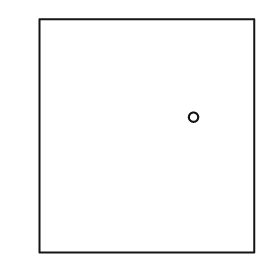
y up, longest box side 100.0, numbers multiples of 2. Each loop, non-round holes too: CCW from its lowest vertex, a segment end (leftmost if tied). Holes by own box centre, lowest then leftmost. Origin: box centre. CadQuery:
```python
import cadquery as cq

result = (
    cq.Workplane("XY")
    .moveTo(-46.0, -50.0)
    .lineTo(46.0, -50.0)
    .lineTo(46.0, 50.0)
    .lineTo(-46.0, 50.0)
    .close()
    .moveTo(20.0, 8.0)
    .circle(2.0)
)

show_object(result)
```